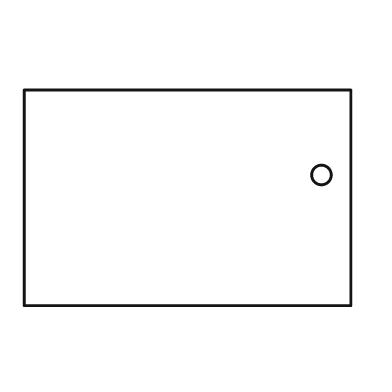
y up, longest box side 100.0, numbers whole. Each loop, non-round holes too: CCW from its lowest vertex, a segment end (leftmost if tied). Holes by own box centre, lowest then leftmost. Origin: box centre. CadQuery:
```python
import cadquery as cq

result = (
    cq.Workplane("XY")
    .moveTo(-50.0, -33.0)
    .lineTo(50.0, -33.0)
    .lineTo(50.0, 33.0)
    .lineTo(-50.0, 33.0)
    .close()
    .moveTo(41.0, 7.0)
    .circle(3.0)
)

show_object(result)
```